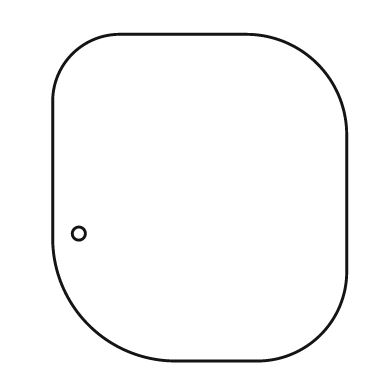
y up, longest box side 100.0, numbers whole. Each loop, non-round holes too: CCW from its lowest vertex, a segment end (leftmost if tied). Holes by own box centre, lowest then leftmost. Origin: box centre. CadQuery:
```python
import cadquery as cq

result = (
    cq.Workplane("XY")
    .moveTo(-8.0, -50.0)
    .lineTo(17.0, -50.0)
    .threePointArc((37.0, -42.0), (45.0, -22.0))
    .lineTo(45.0, 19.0)
    .threePointArc((36.0, 41.0), (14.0, 50.0))
    .lineTo(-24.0, 50.0)
    .threePointArc((-39.0, 44.0), (-45.0, 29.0))
    .lineTo(-45.0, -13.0)
    .threePointArc((-34.0, -39.0), (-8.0, -50.0))
    .close()
    .moveTo(-37.0, -11.0)
    .circle(2.0)
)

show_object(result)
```